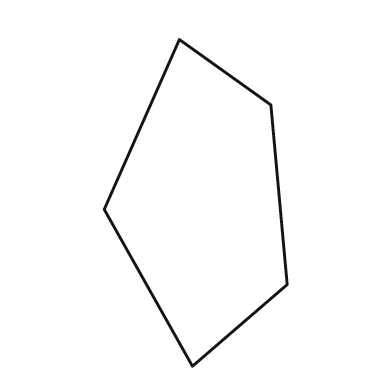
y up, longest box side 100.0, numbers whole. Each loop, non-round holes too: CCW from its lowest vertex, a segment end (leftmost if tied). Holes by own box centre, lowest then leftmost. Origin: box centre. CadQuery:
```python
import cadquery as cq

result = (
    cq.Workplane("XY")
    .moveTo(-1.0, -50.0)
    .lineTo(28.0, -25.0)
    .lineTo(23.0, 30.0)
    .lineTo(-5.0, 50.0)
    .lineTo(-28.0, -2.0)
    .close()
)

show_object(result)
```